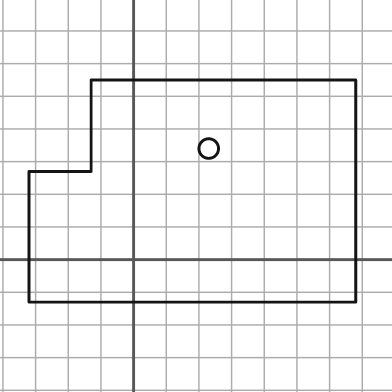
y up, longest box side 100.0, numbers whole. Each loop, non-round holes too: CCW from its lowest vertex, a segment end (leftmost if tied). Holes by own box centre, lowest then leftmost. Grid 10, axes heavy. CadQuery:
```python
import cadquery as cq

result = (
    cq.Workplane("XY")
    .moveTo(-32.0, -13.0)
    .lineTo(68.0, -13.0)
    .lineTo(68.0, 55.0)
    .lineTo(-13.0, 55.0)
    .lineTo(-13.0, 27.0)
    .lineTo(-32.0, 27.0)
    .close()
    .moveTo(23.0, 34.0)
    .circle(3.0)
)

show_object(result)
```